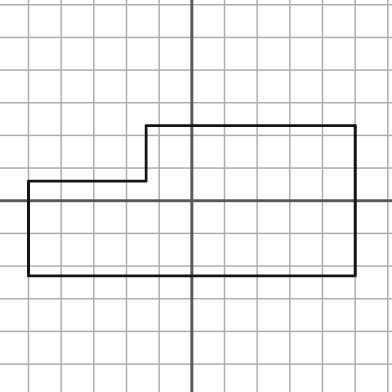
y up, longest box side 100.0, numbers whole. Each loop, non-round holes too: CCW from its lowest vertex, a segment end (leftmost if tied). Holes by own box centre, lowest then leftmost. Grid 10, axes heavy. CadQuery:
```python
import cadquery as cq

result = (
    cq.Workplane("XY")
    .moveTo(-50.0, -23.0)
    .lineTo(50.0, -23.0)
    .lineTo(50.0, 23.0)
    .lineTo(-14.0, 23.0)
    .lineTo(-14.0, 6.0)
    .lineTo(-50.0, 6.0)
    .close()
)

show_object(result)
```